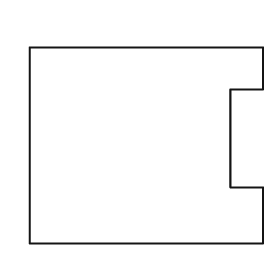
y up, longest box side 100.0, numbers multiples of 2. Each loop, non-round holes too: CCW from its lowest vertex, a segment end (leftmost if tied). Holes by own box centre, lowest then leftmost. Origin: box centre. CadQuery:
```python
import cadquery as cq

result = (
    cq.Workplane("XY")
    .moveTo(-50.0, -42.0)
    .lineTo(50.0, -42.0)
    .lineTo(50.0, -18.0)
    .lineTo(36.0, -18.0)
    .lineTo(36.0, 24.0)
    .lineTo(50.0, 24.0)
    .lineTo(50.0, 42.0)
    .lineTo(-50.0, 42.0)
    .close()
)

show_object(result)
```